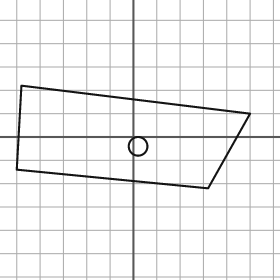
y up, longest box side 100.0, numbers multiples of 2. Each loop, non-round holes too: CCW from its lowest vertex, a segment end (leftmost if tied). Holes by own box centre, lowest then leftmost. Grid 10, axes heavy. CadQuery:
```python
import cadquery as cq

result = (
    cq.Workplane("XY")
    .moveTo(32.0, -22.0)
    .lineTo(50.0, 10.0)
    .lineTo(-48.0, 22.0)
    .lineTo(-50.0, -14.0)
    .close()
    .moveTo(2.0, -4.0)
    .circle(4.0)
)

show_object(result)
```